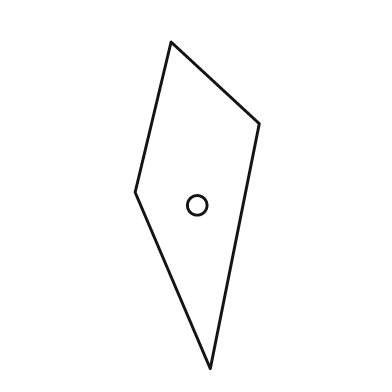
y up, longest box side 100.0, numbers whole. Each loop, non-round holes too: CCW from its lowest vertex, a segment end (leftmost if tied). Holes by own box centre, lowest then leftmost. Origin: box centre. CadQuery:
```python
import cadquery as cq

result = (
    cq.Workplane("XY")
    .moveTo(4.0, -50.0)
    .lineTo(19.0, 25.0)
    .lineTo(-8.0, 50.0)
    .lineTo(-19.0, 4.0)
    .close()
    .moveTo(0.0, 0.0)
    .circle(3.0)
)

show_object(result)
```